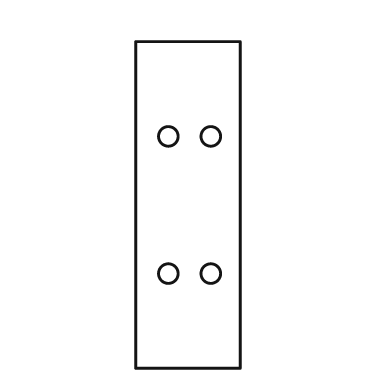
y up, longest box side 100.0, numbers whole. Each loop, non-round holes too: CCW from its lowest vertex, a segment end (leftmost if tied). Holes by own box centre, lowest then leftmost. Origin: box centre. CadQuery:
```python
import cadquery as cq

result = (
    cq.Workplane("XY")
    .moveTo(-16.0, -50.0)
    .lineTo(16.0, -50.0)
    .lineTo(16.0, 50.0)
    .lineTo(-16.0, 50.0)
    .close()
    .moveTo(-6.0, -21.0)
    .circle(3.0)
    .moveTo(7.0, -21.0)
    .circle(3.0)
    .moveTo(-6.0, 21.0)
    .circle(3.0)
    .moveTo(7.0, 21.0)
    .circle(3.0)
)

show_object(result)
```